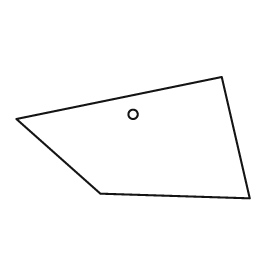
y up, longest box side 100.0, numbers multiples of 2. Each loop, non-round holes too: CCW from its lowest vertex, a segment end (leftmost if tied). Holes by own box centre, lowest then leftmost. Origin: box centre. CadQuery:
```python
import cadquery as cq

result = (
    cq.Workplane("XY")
    .moveTo(50.0, -26.0)
    .lineTo(38.0, 26.0)
    .lineTo(-50.0, 8.0)
    .lineTo(-14.0, -24.0)
    .close()
    .moveTo(0.0, 10.0)
    .circle(2.0)
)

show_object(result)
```